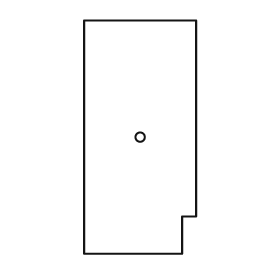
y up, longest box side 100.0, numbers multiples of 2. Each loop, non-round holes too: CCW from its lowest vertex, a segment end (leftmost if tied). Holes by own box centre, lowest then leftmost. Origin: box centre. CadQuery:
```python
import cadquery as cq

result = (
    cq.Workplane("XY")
    .moveTo(-24.0, -50.0)
    .lineTo(18.0, -50.0)
    .lineTo(18.0, -34.0)
    .lineTo(24.0, -34.0)
    .lineTo(24.0, 50.0)
    .lineTo(-24.0, 50.0)
    .close()
    .moveTo(0.0, 0.0)
    .circle(2.0)
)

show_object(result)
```